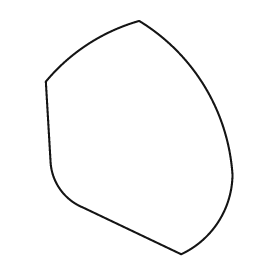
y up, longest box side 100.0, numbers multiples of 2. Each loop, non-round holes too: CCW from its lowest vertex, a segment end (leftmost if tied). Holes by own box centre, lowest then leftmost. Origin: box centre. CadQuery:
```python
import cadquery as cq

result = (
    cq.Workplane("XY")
    .moveTo(18.0, -50.0)
    .threePointArc((34.0, -36.0), (40.0, -16.0))
    .threePointArc((28.0, 22.0), (0.0, 50.0))
    .threePointArc((-22.0, 40.0), (-40.0, 24.0))
    .lineTo(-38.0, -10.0)
    .threePointArc((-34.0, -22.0), (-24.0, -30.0))
    .close()
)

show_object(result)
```